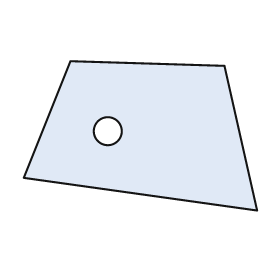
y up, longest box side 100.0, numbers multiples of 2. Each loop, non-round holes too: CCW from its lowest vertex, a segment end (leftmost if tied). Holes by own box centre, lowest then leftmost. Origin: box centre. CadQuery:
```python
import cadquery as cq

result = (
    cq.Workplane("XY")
    .moveTo(50.0, -32.0)
    .lineTo(36.0, 30.0)
    .lineTo(-30.0, 32.0)
    .lineTo(-50.0, -18.0)
    .close()
    .moveTo(-14.0, 2.0)
    .circle(6.0)
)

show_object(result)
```